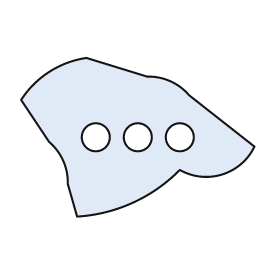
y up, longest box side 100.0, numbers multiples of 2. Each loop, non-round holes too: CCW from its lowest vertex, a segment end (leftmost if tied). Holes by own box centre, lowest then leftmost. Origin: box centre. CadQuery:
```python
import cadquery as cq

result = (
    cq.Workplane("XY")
    .moveTo(-26.0, -34.0)
    .threePointArc((-2.0, -28.0), (18.0, -14.0))
    .threePointArc((36.0, -16.0), (50.0, -4.0))
    .lineTo(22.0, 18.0)
    .threePointArc((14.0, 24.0), (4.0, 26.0))
    .lineTo(-22.0, 34.0)
    .threePointArc((-38.0, 28.0), (-50.0, 16.0))
    .lineTo(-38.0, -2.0)
    .threePointArc((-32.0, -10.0), (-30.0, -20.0))
    .close()
    .moveTo(-18.0, 0.0)
    .circle(6.0)
    .moveTo(0.0, 0.0)
    .circle(6.0)
    .moveTo(18.0, 0.0)
    .circle(6.0)
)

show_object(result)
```